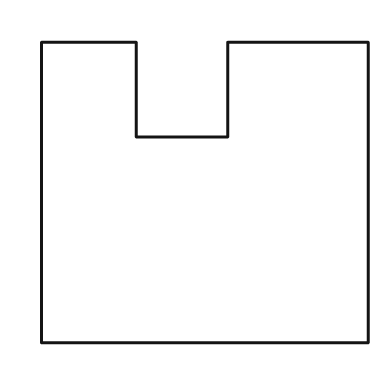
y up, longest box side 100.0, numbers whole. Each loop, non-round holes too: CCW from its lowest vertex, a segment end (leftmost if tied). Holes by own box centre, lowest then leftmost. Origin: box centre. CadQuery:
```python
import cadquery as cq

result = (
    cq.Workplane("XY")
    .moveTo(-50.0, -46.0)
    .lineTo(50.0, -46.0)
    .lineTo(50.0, 46.0)
    .lineTo(7.0, 46.0)
    .lineTo(7.0, 17.0)
    .lineTo(-21.0, 17.0)
    .lineTo(-21.0, 46.0)
    .lineTo(-50.0, 46.0)
    .close()
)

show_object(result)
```